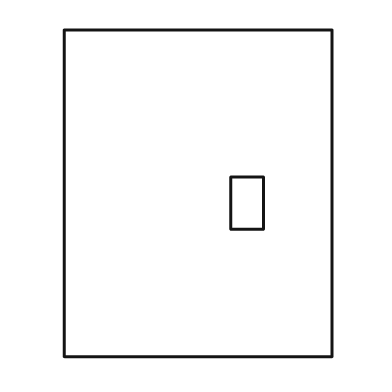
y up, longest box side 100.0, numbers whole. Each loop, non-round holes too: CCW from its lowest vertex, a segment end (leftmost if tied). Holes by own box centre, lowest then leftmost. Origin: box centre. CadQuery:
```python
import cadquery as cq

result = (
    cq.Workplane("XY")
    .moveTo(-41.0, -50.0)
    .lineTo(41.0, -50.0)
    .lineTo(41.0, 50.0)
    .lineTo(-41.0, 50.0)
    .close()
    .moveTo(10.0, -11.0)
    .lineTo(20.0, -11.0)
    .lineTo(20.0, 5.0)
    .lineTo(10.0, 5.0)
    .close()
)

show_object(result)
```